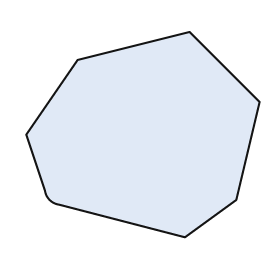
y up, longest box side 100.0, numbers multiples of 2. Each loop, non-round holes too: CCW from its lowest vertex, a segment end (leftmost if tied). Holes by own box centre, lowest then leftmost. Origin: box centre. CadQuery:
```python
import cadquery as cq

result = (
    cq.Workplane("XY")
    .moveTo(18.0, -44.0)
    .lineTo(40.0, -28.0)
    .lineTo(50.0, 14.0)
    .lineTo(20.0, 44.0)
    .lineTo(-28.0, 32.0)
    .lineTo(-50.0, 0.0)
    .lineTo(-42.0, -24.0)
    .threePointArc((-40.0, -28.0), (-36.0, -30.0))
    .close()
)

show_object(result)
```